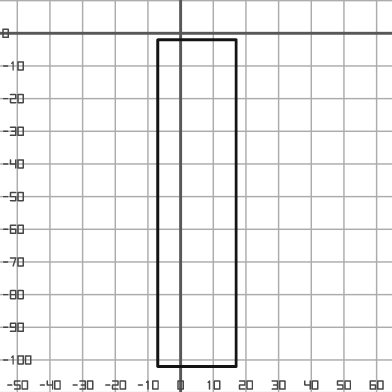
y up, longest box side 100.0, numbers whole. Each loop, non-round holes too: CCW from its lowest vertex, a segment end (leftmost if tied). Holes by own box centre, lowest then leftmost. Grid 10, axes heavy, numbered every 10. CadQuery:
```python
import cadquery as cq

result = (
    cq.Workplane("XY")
    .moveTo(-7.0, -102.0)
    .lineTo(17.0, -102.0)
    .lineTo(17.0, -2.0)
    .lineTo(-7.0, -2.0)
    .close()
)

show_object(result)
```